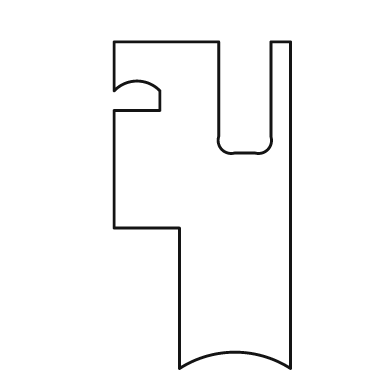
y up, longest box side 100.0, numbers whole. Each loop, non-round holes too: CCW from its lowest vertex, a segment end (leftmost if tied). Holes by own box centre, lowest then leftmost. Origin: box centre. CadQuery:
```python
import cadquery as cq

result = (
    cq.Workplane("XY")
    .moveTo(-7.0, -50.0)
    .threePointArc((10.0, -45.0), (27.0, -50.0))
    .lineTo(27.0, 50.0)
    .lineTo(21.0, 50.0)
    .lineTo(21.0, 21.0)
    .threePointArc((20.0, 17.0), (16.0, 16.0))
    .lineTo(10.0, 16.0)
    .threePointArc((6.0, 17.0), (5.0, 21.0))
    .lineTo(5.0, 50.0)
    .lineTo(-27.0, 50.0)
    .lineTo(-27.0, 35.0)
    .threePointArc((-20.0, 38.0), (-13.0, 35.0))
    .lineTo(-13.0, 29.0)
    .lineTo(-27.0, 29.0)
    .lineTo(-27.0, -7.0)
    .lineTo(-7.0, -7.0)
    .close()
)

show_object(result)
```